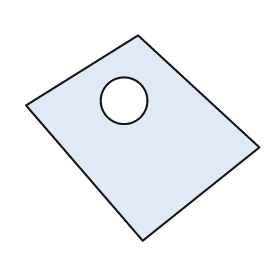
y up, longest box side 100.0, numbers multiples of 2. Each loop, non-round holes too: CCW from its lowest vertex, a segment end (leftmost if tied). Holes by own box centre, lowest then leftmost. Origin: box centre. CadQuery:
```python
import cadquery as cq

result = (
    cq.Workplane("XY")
    .moveTo(0.0, -44.0)
    .lineTo(50.0, -4.0)
    .lineTo(-2.0, 44.0)
    .lineTo(-50.0, 14.0)
    .close()
    .moveTo(-8.0, 16.0)
    .circle(10.0)
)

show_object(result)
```